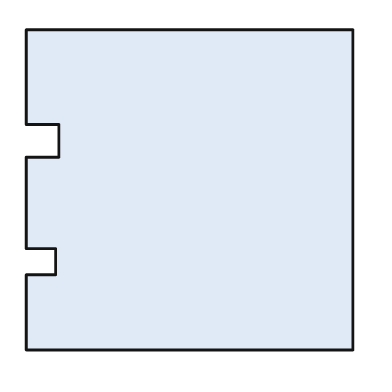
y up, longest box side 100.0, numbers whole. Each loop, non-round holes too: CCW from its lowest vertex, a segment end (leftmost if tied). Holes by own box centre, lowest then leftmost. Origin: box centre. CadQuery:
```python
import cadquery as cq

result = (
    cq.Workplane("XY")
    .moveTo(-50.0, -49.0)
    .lineTo(50.0, -49.0)
    .lineTo(50.0, 49.0)
    .lineTo(-50.0, 49.0)
    .lineTo(-50.0, 20.0)
    .lineTo(-40.0, 20.0)
    .lineTo(-40.0, 10.0)
    .lineTo(-50.0, 10.0)
    .lineTo(-50.0, -18.0)
    .lineTo(-41.0, -18.0)
    .lineTo(-41.0, -26.0)
    .lineTo(-50.0, -26.0)
    .close()
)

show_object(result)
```